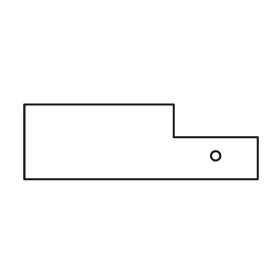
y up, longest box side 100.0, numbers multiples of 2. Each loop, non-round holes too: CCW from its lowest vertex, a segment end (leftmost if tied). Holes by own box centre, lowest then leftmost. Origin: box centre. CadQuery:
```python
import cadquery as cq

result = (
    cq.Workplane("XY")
    .moveTo(-50.0, -16.0)
    .lineTo(50.0, -16.0)
    .lineTo(50.0, 2.0)
    .lineTo(14.0, 2.0)
    .lineTo(14.0, 16.0)
    .lineTo(-50.0, 16.0)
    .close()
    .moveTo(32.0, -6.0)
    .circle(2.0)
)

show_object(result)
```